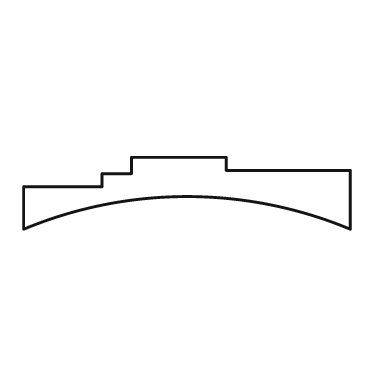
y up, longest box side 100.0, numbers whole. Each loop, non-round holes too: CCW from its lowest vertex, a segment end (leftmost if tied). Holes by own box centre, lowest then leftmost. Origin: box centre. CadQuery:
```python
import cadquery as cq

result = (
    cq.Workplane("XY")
    .moveTo(-50.0, -11.0)
    .threePointArc((0.0, -1.0), (50.0, -11.0))
    .lineTo(50.0, 7.0)
    .lineTo(12.0, 7.0)
    .lineTo(12.0, 11.0)
    .lineTo(-17.0, 11.0)
    .lineTo(-17.0, 6.0)
    .lineTo(-26.0, 6.0)
    .lineTo(-26.0, 2.0)
    .lineTo(-50.0, 2.0)
    .close()
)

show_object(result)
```